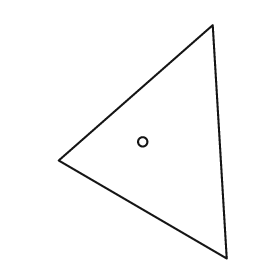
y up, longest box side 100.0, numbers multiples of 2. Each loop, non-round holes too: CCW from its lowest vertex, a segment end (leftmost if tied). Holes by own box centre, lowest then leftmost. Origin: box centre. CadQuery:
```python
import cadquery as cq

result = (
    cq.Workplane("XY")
    .moveTo(36.0, -50.0)
    .lineTo(30.0, 50.0)
    .lineTo(-36.0, -8.0)
    .close()
    .moveTo(0.0, 0.0)
    .circle(2.0)
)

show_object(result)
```